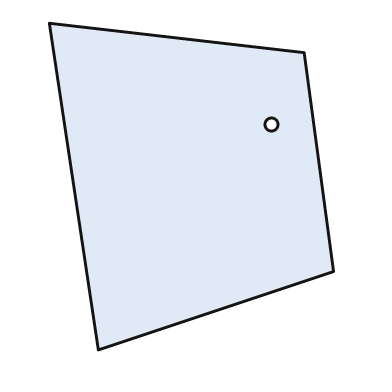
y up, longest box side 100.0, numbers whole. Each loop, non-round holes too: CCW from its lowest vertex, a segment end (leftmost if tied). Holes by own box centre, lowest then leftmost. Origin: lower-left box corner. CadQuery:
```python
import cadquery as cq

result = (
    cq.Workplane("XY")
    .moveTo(15.0, 0.0)
    .lineTo(87.0, 24.0)
    .lineTo(78.0, 91.0)
    .lineTo(0.0, 100.0)
    .close()
    .moveTo(68.0, 69.0)
    .circle(2.0)
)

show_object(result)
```